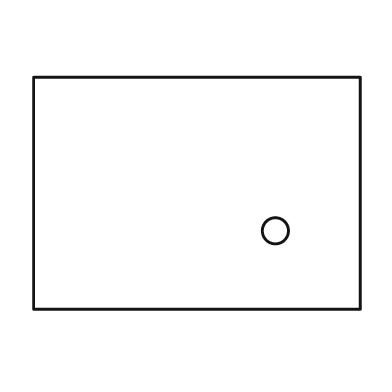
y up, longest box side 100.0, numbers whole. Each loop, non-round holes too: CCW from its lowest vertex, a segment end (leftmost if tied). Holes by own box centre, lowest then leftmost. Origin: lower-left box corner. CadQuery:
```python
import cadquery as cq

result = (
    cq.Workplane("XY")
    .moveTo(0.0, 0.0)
    .lineTo(100.0, 0.0)
    .lineTo(100.0, 71.0)
    .lineTo(0.0, 71.0)
    .close()
    .moveTo(74.0, 24.0)
    .circle(4.0)
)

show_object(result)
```